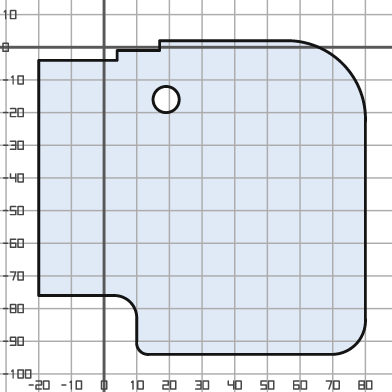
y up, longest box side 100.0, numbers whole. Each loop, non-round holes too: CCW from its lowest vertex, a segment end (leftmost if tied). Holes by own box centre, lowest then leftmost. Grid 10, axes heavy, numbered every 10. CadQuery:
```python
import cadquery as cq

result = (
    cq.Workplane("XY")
    .moveTo(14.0, -94.0)
    .lineTo(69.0, -94.0)
    .threePointArc((77.0, -91.0), (80.0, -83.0))
    .lineTo(80.0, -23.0)
    .threePointArc((73.0, -5.0), (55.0, 2.0))
    .lineTo(17.0, 2.0)
    .lineTo(17.0, -1.0)
    .lineTo(4.0, -1.0)
    .lineTo(4.0, -4.0)
    .lineTo(-20.0, -4.0)
    .lineTo(-20.0, -76.0)
    .lineTo(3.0, -76.0)
    .threePointArc((8.0, -78.0), (10.0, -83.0))
    .lineTo(10.0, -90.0)
    .threePointArc((11.0, -93.0), (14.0, -94.0))
    .close()
    .moveTo(19.0, -16.0)
    .circle(4.0)
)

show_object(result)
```